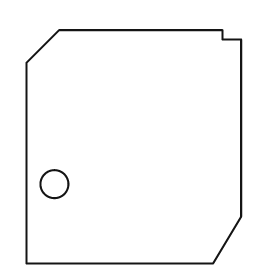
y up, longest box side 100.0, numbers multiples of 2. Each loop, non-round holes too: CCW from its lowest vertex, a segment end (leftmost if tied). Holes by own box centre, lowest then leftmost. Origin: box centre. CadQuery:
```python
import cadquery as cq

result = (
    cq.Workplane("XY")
    .moveTo(-46.0, -50.0)
    .lineTo(34.0, -50.0)
    .lineTo(46.0, -30.0)
    .lineTo(46.0, 46.0)
    .lineTo(38.0, 46.0)
    .lineTo(38.0, 50.0)
    .lineTo(-32.0, 50.0)
    .lineTo(-46.0, 36.0)
    .close()
    .moveTo(-34.0, -16.0)
    .circle(6.0)
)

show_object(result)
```